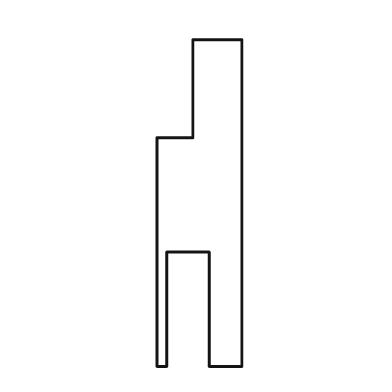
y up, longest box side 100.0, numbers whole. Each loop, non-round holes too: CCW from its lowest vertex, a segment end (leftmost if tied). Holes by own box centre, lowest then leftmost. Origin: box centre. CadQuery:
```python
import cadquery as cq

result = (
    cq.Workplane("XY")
    .moveTo(-13.0, -50.0)
    .lineTo(-10.0, -50.0)
    .lineTo(-10.0, -15.0)
    .lineTo(3.0, -15.0)
    .lineTo(3.0, -50.0)
    .lineTo(13.0, -50.0)
    .lineTo(13.0, 50.0)
    .lineTo(-2.0, 50.0)
    .lineTo(-2.0, 20.0)
    .lineTo(-13.0, 20.0)
    .close()
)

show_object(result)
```